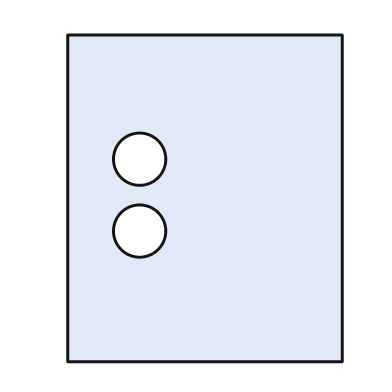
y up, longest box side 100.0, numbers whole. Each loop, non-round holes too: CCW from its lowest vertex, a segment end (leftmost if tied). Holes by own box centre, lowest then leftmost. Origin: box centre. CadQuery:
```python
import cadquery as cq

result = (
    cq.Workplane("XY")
    .moveTo(-42.0, -50.0)
    .lineTo(42.0, -50.0)
    .lineTo(42.0, 50.0)
    .lineTo(-42.0, 50.0)
    .close()
    .moveTo(-20.0, -10.0)
    .circle(8.0)
    .moveTo(-20.0, 12.0)
    .circle(8.0)
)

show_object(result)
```